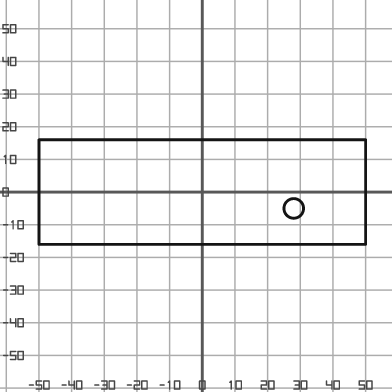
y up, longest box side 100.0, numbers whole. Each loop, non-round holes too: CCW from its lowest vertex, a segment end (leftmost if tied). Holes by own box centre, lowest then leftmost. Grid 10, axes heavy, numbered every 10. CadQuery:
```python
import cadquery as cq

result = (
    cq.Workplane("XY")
    .moveTo(-50.0, -16.0)
    .lineTo(50.0, -16.0)
    .lineTo(50.0, 16.0)
    .lineTo(-50.0, 16.0)
    .close()
    .moveTo(28.0, -5.0)
    .circle(3.0)
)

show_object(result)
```